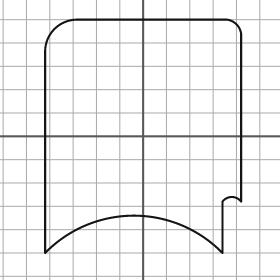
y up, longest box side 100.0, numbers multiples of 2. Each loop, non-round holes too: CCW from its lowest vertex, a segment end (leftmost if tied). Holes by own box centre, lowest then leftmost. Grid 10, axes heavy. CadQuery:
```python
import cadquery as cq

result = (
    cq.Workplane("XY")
    .moveTo(-42.0, -50.0)
    .threePointArc((-4.0, -34.0), (34.0, -50.0))
    .lineTo(34.0, -28.0)
    .threePointArc((38.0, -26.0), (42.0, -28.0))
    .lineTo(42.0, 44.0)
    .threePointArc((40.0, 48.0), (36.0, 50.0))
    .lineTo(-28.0, 50.0)
    .threePointArc((-38.0, 46.0), (-42.0, 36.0))
    .close()
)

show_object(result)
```